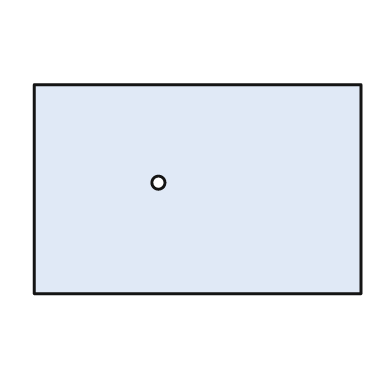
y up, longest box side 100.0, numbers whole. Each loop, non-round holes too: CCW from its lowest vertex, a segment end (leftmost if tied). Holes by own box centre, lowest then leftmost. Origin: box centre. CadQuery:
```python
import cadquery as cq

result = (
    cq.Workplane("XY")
    .moveTo(-50.0, -32.0)
    .lineTo(50.0, -32.0)
    .lineTo(50.0, 32.0)
    .lineTo(-50.0, 32.0)
    .close()
    .moveTo(-12.0, 2.0)
    .circle(2.0)
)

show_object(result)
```